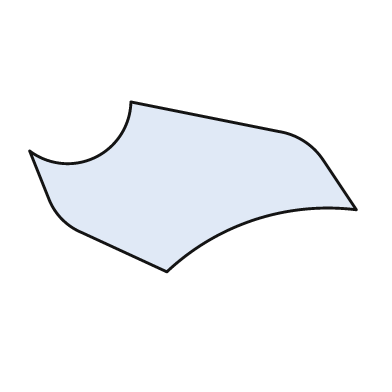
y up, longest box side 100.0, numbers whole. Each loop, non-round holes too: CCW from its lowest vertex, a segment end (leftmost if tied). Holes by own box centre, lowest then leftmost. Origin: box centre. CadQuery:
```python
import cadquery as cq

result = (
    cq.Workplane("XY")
    .moveTo(-8.0, -26.0)
    .threePointArc((19.0, -10.0), (50.0, -7.0))
    .lineTo(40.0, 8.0)
    .threePointArc((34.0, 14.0), (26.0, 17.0))
    .lineTo(-19.0, 26.0)
    .threePointArc((-30.0, 9.0), (-50.0, 11.0))
    .lineTo(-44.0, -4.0)
    .threePointArc((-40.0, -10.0), (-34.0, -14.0))
    .close()
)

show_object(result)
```